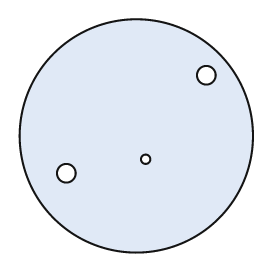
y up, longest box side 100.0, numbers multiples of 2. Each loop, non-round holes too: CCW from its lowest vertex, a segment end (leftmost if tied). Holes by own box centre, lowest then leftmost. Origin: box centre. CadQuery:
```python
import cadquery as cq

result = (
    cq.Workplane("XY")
    .moveTo(0.0, 0.0)
    .circle(50.0)
    .moveTo(-30.0, -16.0)
    .circle(4.0)
    .moveTo(4.0, -10.0)
    .circle(2.0)
    .moveTo(30.0, 26.0)
    .circle(4.0)
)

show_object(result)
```